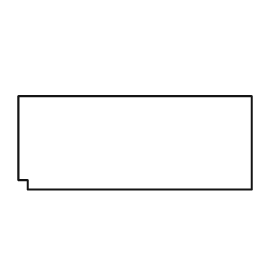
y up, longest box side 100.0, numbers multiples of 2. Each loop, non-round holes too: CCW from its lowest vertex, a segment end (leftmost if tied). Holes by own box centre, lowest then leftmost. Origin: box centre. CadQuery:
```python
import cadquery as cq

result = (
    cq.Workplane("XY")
    .moveTo(-46.0, -20.0)
    .lineTo(50.0, -20.0)
    .lineTo(50.0, 20.0)
    .lineTo(-50.0, 20.0)
    .lineTo(-50.0, -16.0)
    .lineTo(-46.0, -16.0)
    .close()
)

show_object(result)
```